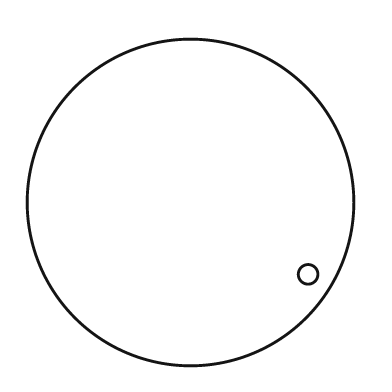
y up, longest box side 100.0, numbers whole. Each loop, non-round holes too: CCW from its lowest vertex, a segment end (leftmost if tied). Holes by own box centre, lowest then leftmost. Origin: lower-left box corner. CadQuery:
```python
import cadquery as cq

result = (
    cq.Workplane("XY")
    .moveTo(50.0, 50.0)
    .circle(50.0)
    .moveTo(86.0, 28.0)
    .circle(3.0)
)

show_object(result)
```